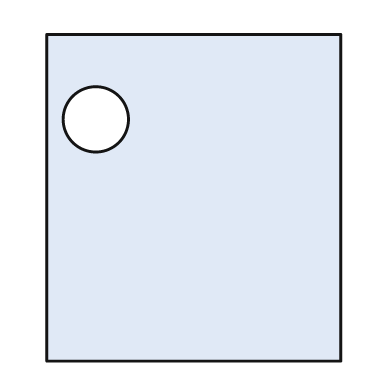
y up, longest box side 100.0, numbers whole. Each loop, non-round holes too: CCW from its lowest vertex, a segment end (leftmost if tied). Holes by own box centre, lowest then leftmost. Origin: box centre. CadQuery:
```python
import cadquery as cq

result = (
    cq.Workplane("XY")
    .moveTo(-45.0, -50.0)
    .lineTo(45.0, -50.0)
    .lineTo(45.0, 50.0)
    .lineTo(-45.0, 50.0)
    .close()
    .moveTo(-30.0, 24.0)
    .circle(10.0)
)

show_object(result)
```